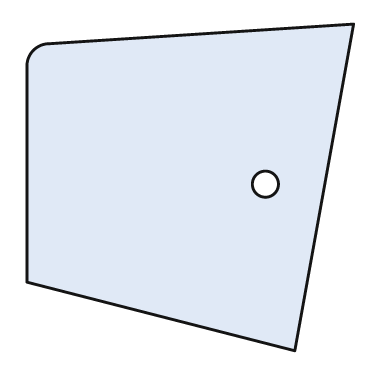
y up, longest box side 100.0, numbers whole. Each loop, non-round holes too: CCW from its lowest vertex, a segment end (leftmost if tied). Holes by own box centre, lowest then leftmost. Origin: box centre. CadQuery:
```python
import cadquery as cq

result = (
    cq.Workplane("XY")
    .moveTo(32.0, -50.0)
    .lineTo(50.0, 50.0)
    .lineTo(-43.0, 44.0)
    .threePointArc((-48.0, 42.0), (-50.0, 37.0))
    .lineTo(-50.0, -29.0)
    .close()
    .moveTo(23.0, 1.0)
    .circle(4.0)
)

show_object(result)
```